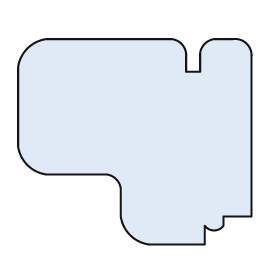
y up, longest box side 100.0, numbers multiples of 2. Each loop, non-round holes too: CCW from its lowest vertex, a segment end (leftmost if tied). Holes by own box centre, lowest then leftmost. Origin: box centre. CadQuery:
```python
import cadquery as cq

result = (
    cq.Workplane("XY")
    .moveTo(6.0, -44.0)
    .lineTo(30.0, -44.0)
    .lineTo(30.0, -36.0)
    .threePointArc((34.0, -38.0), (38.0, -36.0))
    .lineTo(38.0, -32.0)
    .lineTo(50.0, -32.0)
    .lineTo(50.0, 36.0)
    .threePointArc((48.0, 42.0), (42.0, 44.0))
    .lineTo(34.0, 44.0)
    .threePointArc((30.0, 42.0), (28.0, 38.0))
    .lineTo(28.0, 30.0)
    .lineTo(22.0, 30.0)
    .lineTo(22.0, 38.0)
    .threePointArc((20.0, 42.0), (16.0, 44.0))
    .lineTo(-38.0, 44.0)
    .threePointArc((-46.0, 40.0), (-50.0, 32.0))
    .lineTo(-50.0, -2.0)
    .threePointArc((-46.0, -10.0), (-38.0, -14.0))
    .lineTo(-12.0, -14.0)
    .threePointArc((-8.0, -16.0), (-6.0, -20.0))
    .lineTo(-6.0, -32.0)
    .threePointArc((-2.0, -40.0), (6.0, -44.0))
    .close()
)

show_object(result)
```